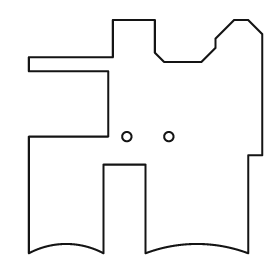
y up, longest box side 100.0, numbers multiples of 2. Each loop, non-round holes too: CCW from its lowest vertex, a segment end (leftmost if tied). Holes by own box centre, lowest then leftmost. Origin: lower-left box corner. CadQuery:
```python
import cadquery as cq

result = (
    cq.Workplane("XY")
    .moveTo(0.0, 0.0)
    .threePointArc((16.0, 4.0), (32.0, 0.0))
    .lineTo(32.0, 38.0)
    .lineTo(50.0, 38.0)
    .lineTo(50.0, 0.0)
    .threePointArc((72.0, 4.0), (94.0, 0.0))
    .lineTo(94.0, 42.0)
    .lineTo(100.0, 42.0)
    .lineTo(100.0, 94.0)
    .lineTo(94.0, 100.0)
    .lineTo(88.0, 100.0)
    .lineTo(80.0, 92.0)
    .lineTo(80.0, 88.0)
    .lineTo(74.0, 82.0)
    .lineTo(58.0, 82.0)
    .lineTo(54.0, 86.0)
    .lineTo(54.0, 100.0)
    .lineTo(36.0, 100.0)
    .lineTo(36.0, 84.0)
    .lineTo(0.0, 84.0)
    .lineTo(0.0, 78.0)
    .lineTo(34.0, 78.0)
    .lineTo(34.0, 50.0)
    .lineTo(0.0, 50.0)
    .close()
    .moveTo(42.0, 50.0)
    .circle(2.0)
    .moveTo(60.0, 50.0)
    .circle(2.0)
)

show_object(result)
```